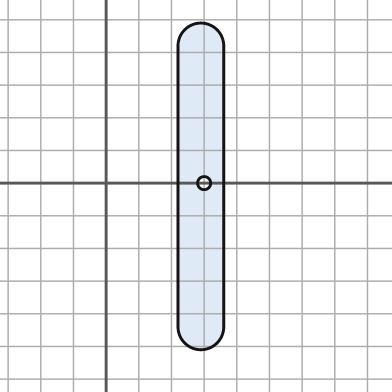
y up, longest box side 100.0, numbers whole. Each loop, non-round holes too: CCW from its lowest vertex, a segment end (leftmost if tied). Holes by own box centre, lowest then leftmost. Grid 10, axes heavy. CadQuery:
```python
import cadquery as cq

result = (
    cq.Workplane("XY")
    .moveTo(22.0, -44.0)
    .threePointArc((29.0, -51.0), (36.0, -44.0))
    .lineTo(36.0, 42.0)
    .threePointArc((29.0, 49.0), (22.0, 42.0))
    .close()
    .moveTo(30.0, 0.0)
    .circle(2.0)
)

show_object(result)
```